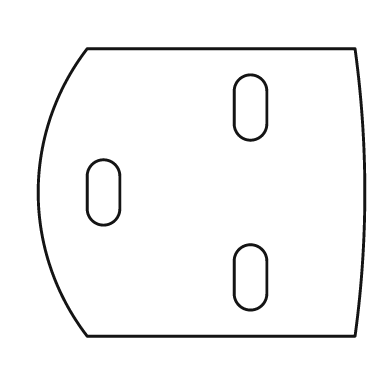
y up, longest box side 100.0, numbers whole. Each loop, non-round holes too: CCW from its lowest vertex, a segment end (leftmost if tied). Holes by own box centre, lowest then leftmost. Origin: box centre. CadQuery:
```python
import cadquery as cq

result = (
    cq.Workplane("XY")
    .moveTo(-35.0, -44.0)
    .lineTo(47.0, -44.0)
    .threePointArc((50.0, 0.0), (47.0, 44.0))
    .lineTo(-35.0, 44.0)
    .threePointArc((-50.0, 0.0), (-35.0, -44.0))
    .close()
    .moveTo(10.0, -31.0)
    .threePointArc((15.0, -36.0), (20.0, -31.0))
    .lineTo(20.0, -21.0)
    .threePointArc((15.0, -16.0), (10.0, -21.0))
    .close()
    .moveTo(-35.0, -5.0)
    .threePointArc((-30.0, -10.0), (-25.0, -5.0))
    .lineTo(-25.0, 5.0)
    .threePointArc((-30.0, 10.0), (-35.0, 5.0))
    .close()
    .moveTo(10.0, 21.0)
    .threePointArc((15.0, 16.0), (20.0, 21.0))
    .lineTo(20.0, 31.0)
    .threePointArc((15.0, 36.0), (10.0, 31.0))
    .close()
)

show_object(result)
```